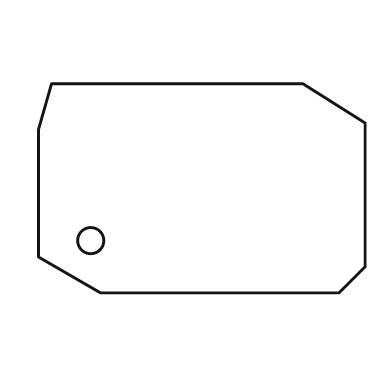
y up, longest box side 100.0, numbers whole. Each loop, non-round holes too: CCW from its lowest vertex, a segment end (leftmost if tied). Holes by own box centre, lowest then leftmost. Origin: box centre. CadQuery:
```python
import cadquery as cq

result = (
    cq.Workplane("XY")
    .moveTo(-31.0, -32.0)
    .lineTo(42.0, -32.0)
    .lineTo(50.0, -24.0)
    .lineTo(50.0, 20.0)
    .lineTo(31.0, 32.0)
    .lineTo(-46.0, 32.0)
    .lineTo(-50.0, 18.0)
    .lineTo(-50.0, -21.0)
    .close()
    .moveTo(-34.0, -16.0)
    .circle(4.0)
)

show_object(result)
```